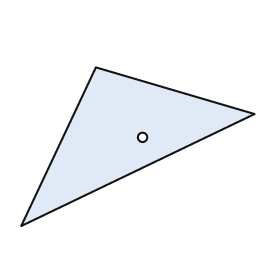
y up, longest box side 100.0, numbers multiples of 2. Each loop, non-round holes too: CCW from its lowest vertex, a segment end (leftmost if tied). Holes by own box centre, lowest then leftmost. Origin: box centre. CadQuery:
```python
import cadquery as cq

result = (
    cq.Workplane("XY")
    .moveTo(-50.0, -34.0)
    .lineTo(50.0, 14.0)
    .lineTo(-18.0, 34.0)
    .close()
    .moveTo(2.0, 4.0)
    .circle(2.0)
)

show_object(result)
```